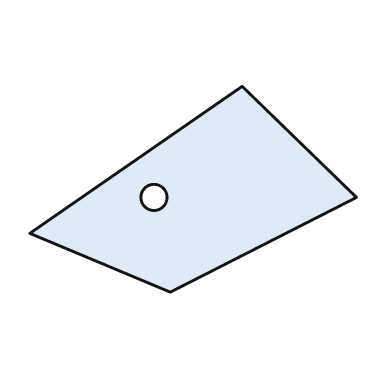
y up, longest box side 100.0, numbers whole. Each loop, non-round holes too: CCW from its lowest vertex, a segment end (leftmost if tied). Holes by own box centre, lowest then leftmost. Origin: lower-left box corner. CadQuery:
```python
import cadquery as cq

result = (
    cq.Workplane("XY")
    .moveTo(43.0, 0.0)
    .lineTo(100.0, 29.0)
    .lineTo(65.0, 63.0)
    .lineTo(0.0, 18.0)
    .close()
    .moveTo(38.0, 29.0)
    .circle(4.0)
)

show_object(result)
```